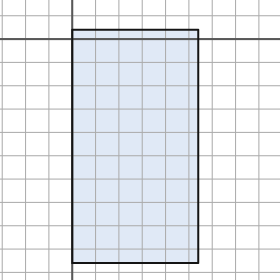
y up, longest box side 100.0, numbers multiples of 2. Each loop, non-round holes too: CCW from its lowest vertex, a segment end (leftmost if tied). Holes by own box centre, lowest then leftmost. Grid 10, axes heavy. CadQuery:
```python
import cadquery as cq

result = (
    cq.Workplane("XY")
    .moveTo(0.0, -96.0)
    .lineTo(54.0, -96.0)
    .lineTo(54.0, 4.0)
    .lineTo(0.0, 4.0)
    .close()
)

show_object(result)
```